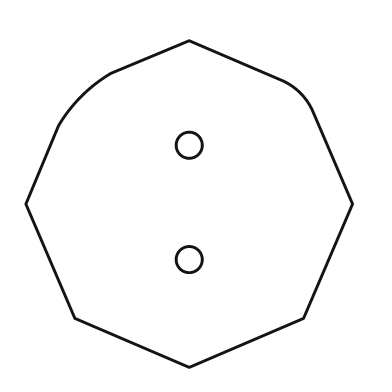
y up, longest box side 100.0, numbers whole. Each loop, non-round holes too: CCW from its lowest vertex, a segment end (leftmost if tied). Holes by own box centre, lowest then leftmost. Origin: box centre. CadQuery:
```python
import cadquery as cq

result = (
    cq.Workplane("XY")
    .moveTo(0.0, -50.0)
    .lineTo(35.0, -35.0)
    .lineTo(50.0, 0.0)
    .lineTo(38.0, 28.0)
    .threePointArc((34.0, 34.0), (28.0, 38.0))
    .lineTo(0.0, 50.0)
    .lineTo(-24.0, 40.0)
    .threePointArc((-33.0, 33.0), (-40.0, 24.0))
    .lineTo(-50.0, 0.0)
    .lineTo(-35.0, -35.0)
    .close()
    .moveTo(0.0, -17.0)
    .circle(4.0)
    .moveTo(0.0, 18.0)
    .circle(4.0)
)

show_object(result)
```